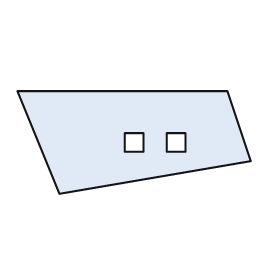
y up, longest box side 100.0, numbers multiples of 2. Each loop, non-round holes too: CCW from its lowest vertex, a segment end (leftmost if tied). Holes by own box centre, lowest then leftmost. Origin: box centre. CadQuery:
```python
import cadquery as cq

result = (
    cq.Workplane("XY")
    .moveTo(-32.0, -22.0)
    .lineTo(50.0, -8.0)
    .lineTo(40.0, 22.0)
    .lineTo(-50.0, 22.0)
    .close()
    .moveTo(-4.0, -4.0)
    .lineTo(4.0, -4.0)
    .lineTo(4.0, 4.0)
    .lineTo(-4.0, 4.0)
    .close()
    .moveTo(14.0, -4.0)
    .lineTo(22.0, -4.0)
    .lineTo(22.0, 4.0)
    .lineTo(14.0, 4.0)
    .close()
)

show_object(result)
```